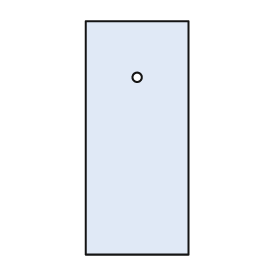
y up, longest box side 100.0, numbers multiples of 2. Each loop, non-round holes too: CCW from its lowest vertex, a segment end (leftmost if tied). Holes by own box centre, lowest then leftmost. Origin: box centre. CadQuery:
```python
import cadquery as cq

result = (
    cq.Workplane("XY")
    .moveTo(-22.0, -50.0)
    .lineTo(22.0, -50.0)
    .lineTo(22.0, 50.0)
    .lineTo(-22.0, 50.0)
    .close()
    .moveTo(0.0, 26.0)
    .circle(2.0)
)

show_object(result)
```